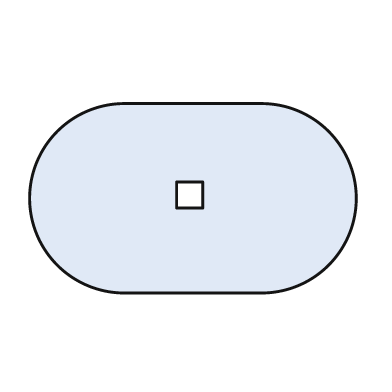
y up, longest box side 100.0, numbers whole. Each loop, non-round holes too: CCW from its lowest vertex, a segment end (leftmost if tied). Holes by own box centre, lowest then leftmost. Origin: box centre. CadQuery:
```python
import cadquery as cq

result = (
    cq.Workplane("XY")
    .moveTo(-21.0, -29.0)
    .lineTo(21.0, -29.0)
    .threePointArc((50.0, 0.0), (21.0, 29.0))
    .lineTo(-21.0, 29.0)
    .threePointArc((-50.0, 0.0), (-21.0, -29.0))
    .close()
    .moveTo(-5.0, -3.0)
    .lineTo(3.0, -3.0)
    .lineTo(3.0, 5.0)
    .lineTo(-5.0, 5.0)
    .close()
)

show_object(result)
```